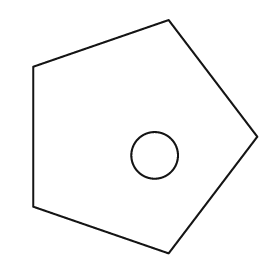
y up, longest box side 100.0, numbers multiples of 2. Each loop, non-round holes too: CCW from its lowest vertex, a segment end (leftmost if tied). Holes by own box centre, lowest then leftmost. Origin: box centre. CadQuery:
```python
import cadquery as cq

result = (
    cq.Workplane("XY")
    .moveTo(10.0, -50.0)
    .lineTo(48.0, 0.0)
    .lineTo(10.0, 50.0)
    .lineTo(-48.0, 30.0)
    .lineTo(-48.0, -30.0)
    .close()
    .moveTo(4.0, -8.0)
    .circle(10.0)
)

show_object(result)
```